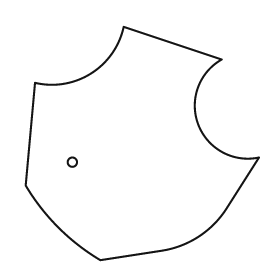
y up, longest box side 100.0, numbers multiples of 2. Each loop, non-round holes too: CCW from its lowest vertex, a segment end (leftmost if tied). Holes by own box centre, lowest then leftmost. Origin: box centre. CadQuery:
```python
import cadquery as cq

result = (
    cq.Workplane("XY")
    .moveTo(-18.0, -50.0)
    .lineTo(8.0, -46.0)
    .threePointArc((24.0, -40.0), (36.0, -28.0))
    .lineTo(50.0, -6.0)
    .threePointArc((24.0, 8.0), (34.0, 36.0))
    .lineTo(-8.0, 50.0)
    .threePointArc((-22.0, 30.0), (-46.0, 26.0))
    .lineTo(-50.0, -18.0)
    .threePointArc((-36.0, -36.0), (-18.0, -50.0))
    .close()
    .moveTo(-30.0, -8.0)
    .circle(2.0)
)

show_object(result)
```